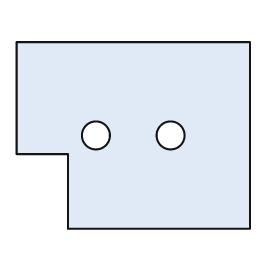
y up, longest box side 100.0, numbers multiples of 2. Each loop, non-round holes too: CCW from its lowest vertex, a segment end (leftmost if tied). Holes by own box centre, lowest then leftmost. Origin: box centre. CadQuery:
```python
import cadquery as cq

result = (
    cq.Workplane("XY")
    .moveTo(-28.0, -40.0)
    .lineTo(50.0, -40.0)
    .lineTo(50.0, 40.0)
    .lineTo(-50.0, 40.0)
    .lineTo(-50.0, -8.0)
    .lineTo(-28.0, -8.0)
    .close()
    .moveTo(-16.0, 0.0)
    .circle(6.0)
    .moveTo(16.0, 0.0)
    .circle(6.0)
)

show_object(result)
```